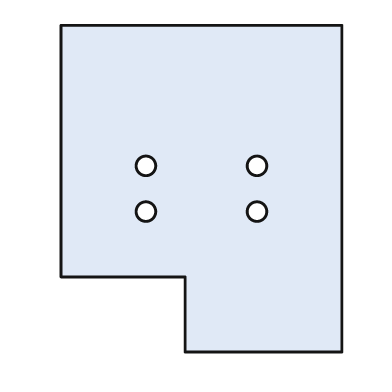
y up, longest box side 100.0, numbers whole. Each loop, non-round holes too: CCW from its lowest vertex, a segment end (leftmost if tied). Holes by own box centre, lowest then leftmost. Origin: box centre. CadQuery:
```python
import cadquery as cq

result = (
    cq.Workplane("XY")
    .moveTo(-5.0, -50.0)
    .lineTo(43.0, -50.0)
    .lineTo(43.0, 50.0)
    .lineTo(-43.0, 50.0)
    .lineTo(-43.0, -27.0)
    .lineTo(-5.0, -27.0)
    .close()
    .moveTo(-17.0, -7.0)
    .circle(3.0)
    .moveTo(17.0, -7.0)
    .circle(3.0)
    .moveTo(-17.0, 7.0)
    .circle(3.0)
    .moveTo(17.0, 7.0)
    .circle(3.0)
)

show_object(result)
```